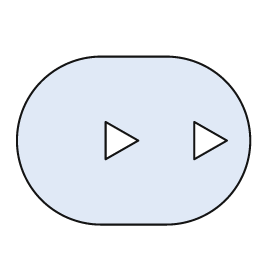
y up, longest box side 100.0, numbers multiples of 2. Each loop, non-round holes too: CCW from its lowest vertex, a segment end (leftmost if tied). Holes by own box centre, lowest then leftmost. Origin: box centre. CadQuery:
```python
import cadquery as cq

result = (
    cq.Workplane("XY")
    .moveTo(-14.0, -36.0)
    .lineTo(14.0, -36.0)
    .threePointArc((50.0, 0.0), (14.0, 36.0))
    .lineTo(-14.0, 36.0)
    .threePointArc((-50.0, 0.0), (-14.0, -36.0))
    .close()
    .moveTo(-12.0, -8.0)
    .lineTo(2.0, 0.0)
    .lineTo(-12.0, 8.0)
    .close()
    .moveTo(26.0, -8.0)
    .lineTo(40.0, 0.0)
    .lineTo(26.0, 8.0)
    .close()
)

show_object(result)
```